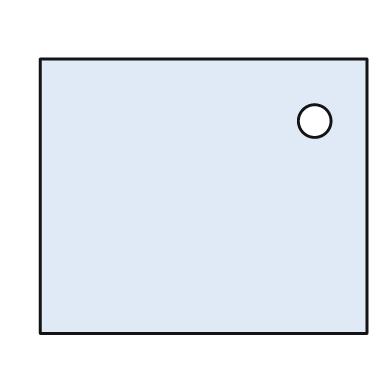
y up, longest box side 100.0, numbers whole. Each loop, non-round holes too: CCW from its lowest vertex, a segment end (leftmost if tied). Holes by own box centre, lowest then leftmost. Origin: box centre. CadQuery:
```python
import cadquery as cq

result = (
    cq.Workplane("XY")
    .moveTo(-50.0, -42.0)
    .lineTo(50.0, -42.0)
    .lineTo(50.0, 42.0)
    .lineTo(-50.0, 42.0)
    .close()
    .moveTo(34.0, 23.0)
    .circle(5.0)
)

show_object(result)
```